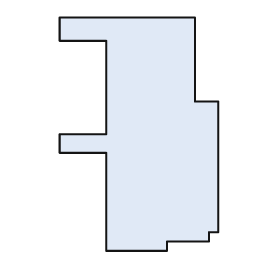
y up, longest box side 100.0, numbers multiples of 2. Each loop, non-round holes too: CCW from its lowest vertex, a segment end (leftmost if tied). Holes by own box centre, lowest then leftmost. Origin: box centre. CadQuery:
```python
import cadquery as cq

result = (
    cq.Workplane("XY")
    .moveTo(-14.0, -50.0)
    .lineTo(12.0, -50.0)
    .lineTo(12.0, -46.0)
    .lineTo(30.0, -46.0)
    .lineTo(30.0, -42.0)
    .lineTo(34.0, -42.0)
    .lineTo(34.0, 14.0)
    .lineTo(24.0, 14.0)
    .lineTo(24.0, 50.0)
    .lineTo(-34.0, 50.0)
    .lineTo(-34.0, 40.0)
    .lineTo(-14.0, 40.0)
    .lineTo(-14.0, 0.0)
    .lineTo(-34.0, 0.0)
    .lineTo(-34.0, -8.0)
    .lineTo(-14.0, -8.0)
    .close()
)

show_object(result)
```